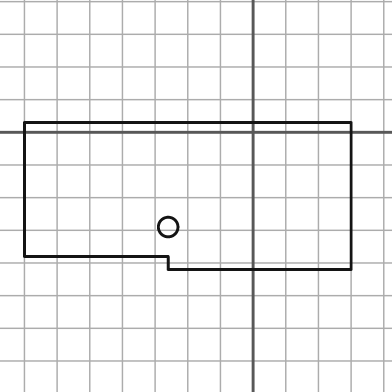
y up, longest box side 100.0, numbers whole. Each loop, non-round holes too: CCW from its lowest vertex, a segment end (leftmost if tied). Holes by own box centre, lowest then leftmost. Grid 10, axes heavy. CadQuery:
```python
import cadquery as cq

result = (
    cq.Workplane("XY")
    .moveTo(-26.0, -42.0)
    .lineTo(30.0, -42.0)
    .lineTo(30.0, 3.0)
    .lineTo(-70.0, 3.0)
    .lineTo(-70.0, -38.0)
    .lineTo(-26.0, -38.0)
    .close()
    .moveTo(-26.0, -29.0)
    .circle(3.0)
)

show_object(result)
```